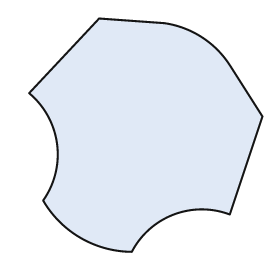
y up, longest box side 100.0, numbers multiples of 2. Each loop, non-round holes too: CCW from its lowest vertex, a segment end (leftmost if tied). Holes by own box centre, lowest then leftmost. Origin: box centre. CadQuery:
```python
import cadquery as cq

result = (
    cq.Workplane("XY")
    .moveTo(-6.0, -50.0)
    .threePointArc((12.0, -34.0), (36.0, -34.0))
    .lineTo(50.0, 8.0)
    .lineTo(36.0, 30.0)
    .threePointArc((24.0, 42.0), (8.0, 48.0))
    .lineTo(-20.0, 50.0)
    .lineTo(-50.0, 18.0)
    .threePointArc((-38.0, -4.0), (-44.0, -28.0))
    .threePointArc((-28.0, -44.0), (-6.0, -50.0))
    .close()
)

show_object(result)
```